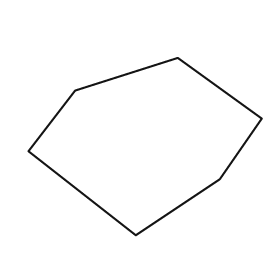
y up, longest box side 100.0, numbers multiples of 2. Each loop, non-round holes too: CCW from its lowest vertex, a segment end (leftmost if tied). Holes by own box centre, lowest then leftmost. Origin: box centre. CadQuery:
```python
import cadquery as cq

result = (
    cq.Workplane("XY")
    .moveTo(-4.0, -38.0)
    .lineTo(32.0, -14.0)
    .lineTo(50.0, 12.0)
    .lineTo(14.0, 38.0)
    .lineTo(-30.0, 24.0)
    .lineTo(-50.0, -2.0)
    .close()
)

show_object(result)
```